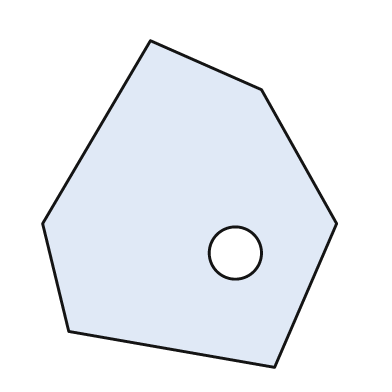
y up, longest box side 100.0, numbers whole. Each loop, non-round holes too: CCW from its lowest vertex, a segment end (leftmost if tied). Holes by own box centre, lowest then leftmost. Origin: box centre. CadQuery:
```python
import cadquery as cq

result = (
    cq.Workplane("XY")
    .moveTo(26.0, -50.0)
    .lineTo(45.0, -6.0)
    .lineTo(22.0, 35.0)
    .lineTo(-12.0, 50.0)
    .lineTo(-45.0, -6.0)
    .lineTo(-37.0, -39.0)
    .close()
    .moveTo(14.0, -15.0)
    .circle(8.0)
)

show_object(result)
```